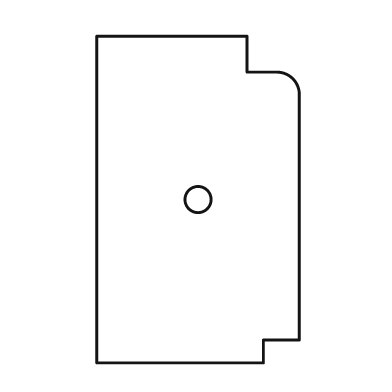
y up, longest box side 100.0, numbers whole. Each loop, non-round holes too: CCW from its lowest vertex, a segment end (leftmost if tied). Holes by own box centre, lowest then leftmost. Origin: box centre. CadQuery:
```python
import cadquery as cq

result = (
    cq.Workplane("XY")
    .moveTo(-31.0, -50.0)
    .lineTo(20.0, -50.0)
    .lineTo(20.0, -43.0)
    .lineTo(31.0, -43.0)
    .lineTo(31.0, 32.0)
    .threePointArc((29.0, 37.0), (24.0, 39.0))
    .lineTo(15.0, 39.0)
    .lineTo(15.0, 50.0)
    .lineTo(-31.0, 50.0)
    .close()
    .moveTo(0.0, 0.0)
    .circle(4.0)
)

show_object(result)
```